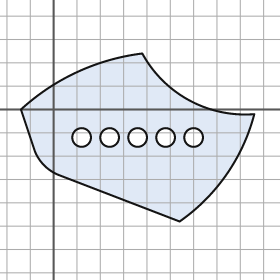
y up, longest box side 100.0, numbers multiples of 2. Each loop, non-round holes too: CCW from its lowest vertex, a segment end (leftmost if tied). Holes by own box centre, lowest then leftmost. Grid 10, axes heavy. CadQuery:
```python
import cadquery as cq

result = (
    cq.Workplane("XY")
    .moveTo(54.0, -48.0)
    .threePointArc((74.0, -28.0), (86.0, -2.0))
    .threePointArc((58.0, 4.0), (38.0, 24.0))
    .threePointArc((10.0, 16.0), (-14.0, 0.0))
    .lineTo(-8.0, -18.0)
    .threePointArc((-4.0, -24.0), (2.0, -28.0))
    .close()
    .moveTo(12.0, -12.0)
    .circle(4.0)
    .moveTo(24.0, -12.0)
    .circle(4.0)
    .moveTo(36.0, -12.0)
    .circle(4.0)
    .moveTo(48.0, -12.0)
    .circle(4.0)
    .moveTo(60.0, -12.0)
    .circle(4.0)
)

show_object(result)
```